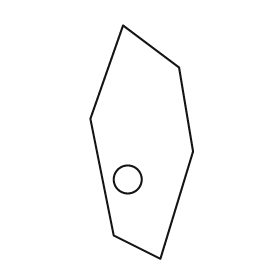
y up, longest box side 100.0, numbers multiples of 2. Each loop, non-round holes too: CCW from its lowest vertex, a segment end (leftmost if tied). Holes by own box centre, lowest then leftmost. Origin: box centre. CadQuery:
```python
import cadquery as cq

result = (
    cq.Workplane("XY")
    .moveTo(8.0, -50.0)
    .lineTo(22.0, -4.0)
    .lineTo(16.0, 32.0)
    .lineTo(-8.0, 50.0)
    .lineTo(-22.0, 10.0)
    .lineTo(-12.0, -40.0)
    .close()
    .moveTo(-6.0, -16.0)
    .circle(6.0)
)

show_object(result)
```